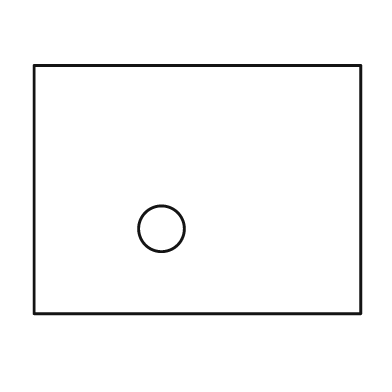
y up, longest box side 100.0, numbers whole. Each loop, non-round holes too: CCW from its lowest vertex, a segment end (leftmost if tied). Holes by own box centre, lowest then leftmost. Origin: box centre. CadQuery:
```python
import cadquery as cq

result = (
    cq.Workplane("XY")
    .moveTo(-50.0, -38.0)
    .lineTo(50.0, -38.0)
    .lineTo(50.0, 38.0)
    .lineTo(-50.0, 38.0)
    .close()
    .moveTo(-11.0, -12.0)
    .circle(7.0)
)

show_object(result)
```